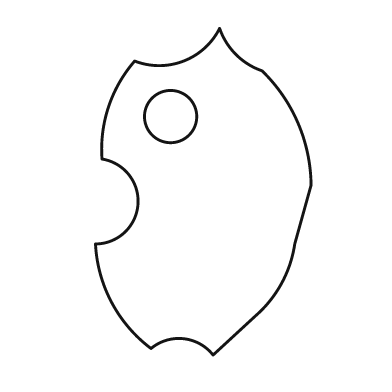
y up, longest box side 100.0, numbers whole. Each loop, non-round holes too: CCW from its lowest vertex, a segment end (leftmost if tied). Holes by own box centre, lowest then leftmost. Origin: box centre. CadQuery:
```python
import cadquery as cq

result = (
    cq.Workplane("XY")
    .moveTo(3.0, -50.0)
    .lineTo(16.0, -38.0)
    .threePointArc((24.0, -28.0), (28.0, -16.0))
    .lineTo(33.0, 2.0)
    .threePointArc((29.0, 21.0), (18.0, 37.0))
    .threePointArc((10.0, 42.0), (5.0, 50.0))
    .threePointArc((-6.0, 40.0), (-21.0, 40.0))
    .threePointArc((-29.0, 26.0), (-31.0, 10.0))
    .threePointArc((-20.0, -4.0), (-33.0, -16.0))
    .threePointArc((-28.0, -34.0), (-16.0, -48.0))
    .threePointArc((-6.0, -45.0), (3.0, -50.0))
    .close()
    .moveTo(-10.0, 23.0)
    .circle(8.0)
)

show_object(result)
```